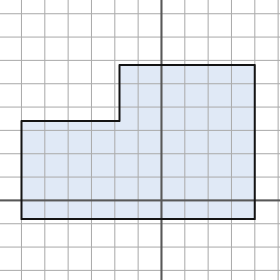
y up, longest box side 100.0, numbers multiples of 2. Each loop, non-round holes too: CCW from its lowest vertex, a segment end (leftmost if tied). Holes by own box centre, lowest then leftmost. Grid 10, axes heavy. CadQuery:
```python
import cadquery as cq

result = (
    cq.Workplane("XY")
    .moveTo(-60.0, -8.0)
    .lineTo(40.0, -8.0)
    .lineTo(40.0, 58.0)
    .lineTo(-18.0, 58.0)
    .lineTo(-18.0, 34.0)
    .lineTo(-60.0, 34.0)
    .close()
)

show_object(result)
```